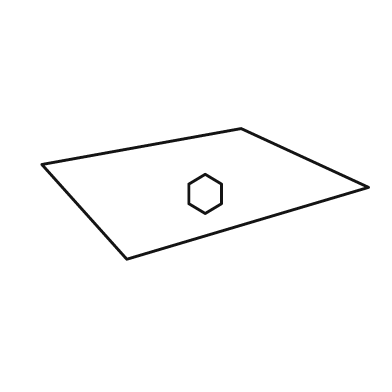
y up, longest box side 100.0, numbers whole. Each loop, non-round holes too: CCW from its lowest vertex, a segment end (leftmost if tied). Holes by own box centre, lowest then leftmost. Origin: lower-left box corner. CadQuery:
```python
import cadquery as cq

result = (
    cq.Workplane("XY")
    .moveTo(26.0, 0.0)
    .lineTo(100.0, 22.0)
    .lineTo(61.0, 40.0)
    .lineTo(0.0, 29.0)
    .close()
    .moveTo(50.0, 14.0)
    .lineTo(55.0, 17.0)
    .lineTo(55.0, 23.0)
    .lineTo(50.0, 26.0)
    .lineTo(45.0, 23.0)
    .lineTo(45.0, 17.0)
    .close()
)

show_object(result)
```